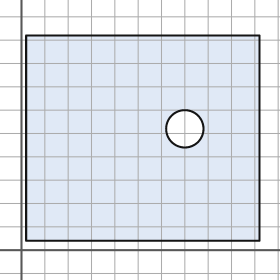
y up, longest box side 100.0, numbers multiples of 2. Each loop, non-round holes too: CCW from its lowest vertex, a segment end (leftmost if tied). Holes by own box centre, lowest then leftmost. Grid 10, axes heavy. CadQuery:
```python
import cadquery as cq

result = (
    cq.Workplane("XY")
    .moveTo(2.0, 4.0)
    .lineTo(102.0, 4.0)
    .lineTo(102.0, 92.0)
    .lineTo(2.0, 92.0)
    .close()
    .moveTo(70.0, 52.0)
    .circle(8.0)
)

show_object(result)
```